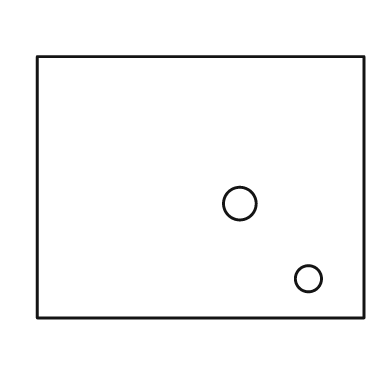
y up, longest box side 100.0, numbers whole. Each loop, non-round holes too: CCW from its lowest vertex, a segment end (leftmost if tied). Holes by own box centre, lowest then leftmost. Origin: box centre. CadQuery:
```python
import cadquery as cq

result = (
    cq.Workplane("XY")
    .moveTo(-50.0, -40.0)
    .lineTo(50.0, -40.0)
    .lineTo(50.0, 40.0)
    .lineTo(-50.0, 40.0)
    .close()
    .moveTo(33.0, -28.0)
    .circle(4.0)
    .moveTo(12.0, -5.0)
    .circle(5.0)
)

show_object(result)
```